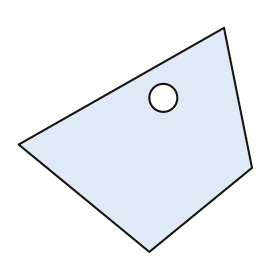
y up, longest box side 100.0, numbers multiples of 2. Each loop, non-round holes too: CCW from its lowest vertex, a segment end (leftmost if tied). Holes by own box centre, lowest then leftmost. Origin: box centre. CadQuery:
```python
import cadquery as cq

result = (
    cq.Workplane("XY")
    .moveTo(6.0, -48.0)
    .lineTo(50.0, -12.0)
    .lineTo(38.0, 48.0)
    .lineTo(-50.0, -2.0)
    .close()
    .moveTo(12.0, 18.0)
    .circle(6.0)
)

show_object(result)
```